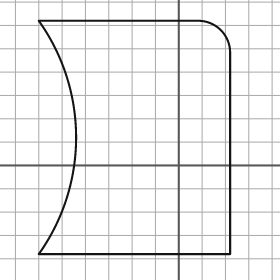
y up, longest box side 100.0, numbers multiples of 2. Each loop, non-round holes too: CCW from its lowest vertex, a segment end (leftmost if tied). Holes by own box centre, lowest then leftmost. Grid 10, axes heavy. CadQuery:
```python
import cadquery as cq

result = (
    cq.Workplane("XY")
    .moveTo(-60.0, -38.0)
    .lineTo(22.0, -38.0)
    .lineTo(22.0, 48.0)
    .threePointArc((18.0, 58.0), (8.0, 62.0))
    .lineTo(-60.0, 62.0)
    .threePointArc((-44.0, 12.0), (-60.0, -38.0))
    .close()
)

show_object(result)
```